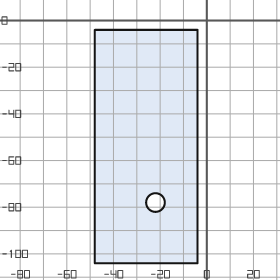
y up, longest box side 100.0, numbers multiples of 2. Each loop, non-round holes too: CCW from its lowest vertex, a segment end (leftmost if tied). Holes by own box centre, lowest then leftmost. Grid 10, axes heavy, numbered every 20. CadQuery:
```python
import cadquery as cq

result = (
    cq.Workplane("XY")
    .moveTo(-48.0, -104.0)
    .lineTo(-4.0, -104.0)
    .lineTo(-4.0, -4.0)
    .lineTo(-48.0, -4.0)
    .close()
    .moveTo(-22.0, -78.0)
    .circle(4.0)
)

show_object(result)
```